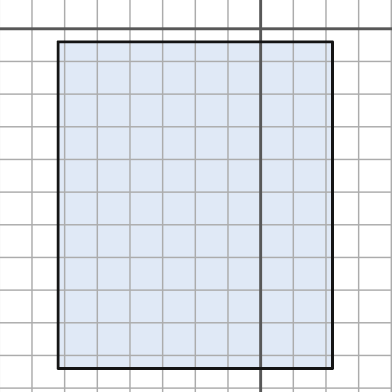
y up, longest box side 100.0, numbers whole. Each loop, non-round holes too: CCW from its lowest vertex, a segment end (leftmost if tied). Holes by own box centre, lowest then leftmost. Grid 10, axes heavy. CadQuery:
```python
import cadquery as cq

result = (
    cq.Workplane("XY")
    .moveTo(-62.0, -104.0)
    .lineTo(22.0, -104.0)
    .lineTo(22.0, -4.0)
    .lineTo(-62.0, -4.0)
    .close()
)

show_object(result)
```